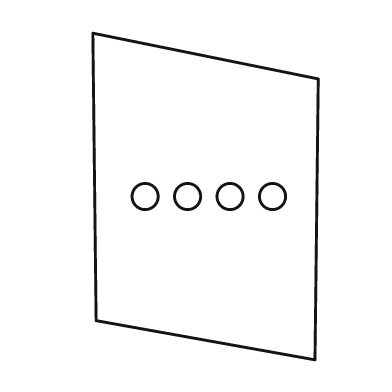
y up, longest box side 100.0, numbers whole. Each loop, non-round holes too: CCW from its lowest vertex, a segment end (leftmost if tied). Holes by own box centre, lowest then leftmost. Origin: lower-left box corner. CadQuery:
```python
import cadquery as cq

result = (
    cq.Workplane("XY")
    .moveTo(68.0, 0.0)
    .lineTo(69.0, 86.0)
    .lineTo(0.0, 100.0)
    .lineTo(1.0, 12.0)
    .close()
    .moveTo(16.0, 50.0)
    .circle(4.0)
    .moveTo(29.0, 50.0)
    .circle(4.0)
    .moveTo(42.0, 50.0)
    .circle(4.0)
    .moveTo(55.0, 50.0)
    .circle(4.0)
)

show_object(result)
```